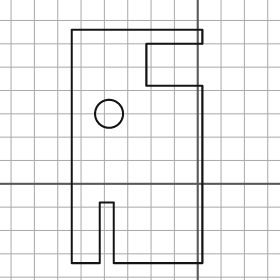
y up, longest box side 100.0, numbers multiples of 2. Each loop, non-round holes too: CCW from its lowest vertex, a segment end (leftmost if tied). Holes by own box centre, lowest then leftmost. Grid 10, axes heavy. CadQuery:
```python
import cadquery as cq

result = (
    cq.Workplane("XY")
    .moveTo(-54.0, -34.0)
    .lineTo(-42.0, -34.0)
    .lineTo(-42.0, -8.0)
    .lineTo(-36.0, -8.0)
    .lineTo(-36.0, -34.0)
    .lineTo(2.0, -34.0)
    .lineTo(2.0, 42.0)
    .lineTo(-22.0, 42.0)
    .lineTo(-22.0, 60.0)
    .lineTo(2.0, 60.0)
    .lineTo(2.0, 66.0)
    .lineTo(-54.0, 66.0)
    .close()
    .moveTo(-38.0, 30.0)
    .circle(6.0)
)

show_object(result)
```